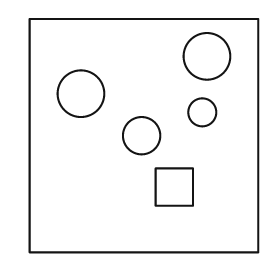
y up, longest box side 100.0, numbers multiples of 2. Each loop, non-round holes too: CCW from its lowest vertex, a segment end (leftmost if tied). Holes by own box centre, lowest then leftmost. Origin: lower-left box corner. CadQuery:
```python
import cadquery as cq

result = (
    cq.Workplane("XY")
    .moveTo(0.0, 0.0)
    .lineTo(98.0, 0.0)
    .lineTo(98.0, 100.0)
    .lineTo(0.0, 100.0)
    .close()
    .moveTo(54.0, 20.0)
    .lineTo(70.0, 20.0)
    .lineTo(70.0, 36.0)
    .lineTo(54.0, 36.0)
    .close()
    .moveTo(48.0, 50.0)
    .circle(8.0)
    .moveTo(74.0, 60.0)
    .circle(6.0)
    .moveTo(22.0, 68.0)
    .circle(10.0)
    .moveTo(76.0, 84.0)
    .circle(10.0)
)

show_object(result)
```